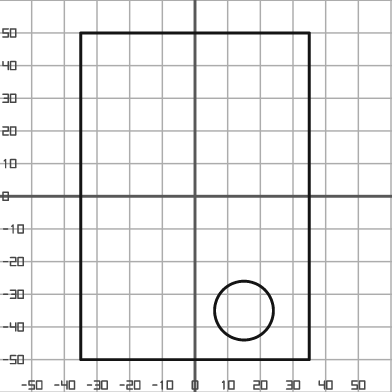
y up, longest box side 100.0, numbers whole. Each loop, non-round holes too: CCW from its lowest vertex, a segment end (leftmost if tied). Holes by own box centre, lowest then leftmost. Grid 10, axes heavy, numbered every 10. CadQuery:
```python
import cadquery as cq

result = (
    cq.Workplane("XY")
    .moveTo(-35.0, -50.0)
    .lineTo(35.0, -50.0)
    .lineTo(35.0, 50.0)
    .lineTo(-35.0, 50.0)
    .close()
    .moveTo(15.0, -35.0)
    .circle(9.0)
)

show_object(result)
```